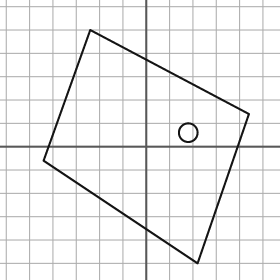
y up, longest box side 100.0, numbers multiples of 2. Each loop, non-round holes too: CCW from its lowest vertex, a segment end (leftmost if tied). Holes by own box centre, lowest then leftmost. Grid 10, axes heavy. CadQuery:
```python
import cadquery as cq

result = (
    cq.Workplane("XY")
    .moveTo(22.0, -50.0)
    .lineTo(44.0, 14.0)
    .lineTo(-24.0, 50.0)
    .lineTo(-44.0, -6.0)
    .close()
    .moveTo(18.0, 6.0)
    .circle(4.0)
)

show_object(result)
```